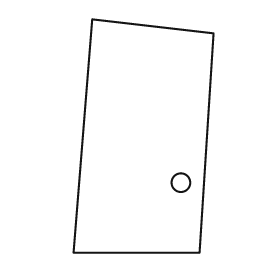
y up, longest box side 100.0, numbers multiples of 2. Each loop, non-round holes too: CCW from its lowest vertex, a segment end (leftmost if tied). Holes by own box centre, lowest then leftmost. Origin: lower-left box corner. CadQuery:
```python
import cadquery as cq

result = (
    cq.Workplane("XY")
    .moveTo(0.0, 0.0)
    .lineTo(54.0, 0.0)
    .lineTo(60.0, 94.0)
    .lineTo(8.0, 100.0)
    .close()
    .moveTo(46.0, 30.0)
    .circle(4.0)
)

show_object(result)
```